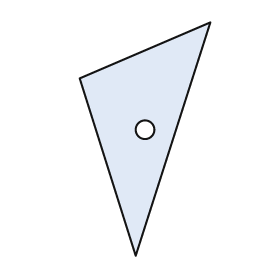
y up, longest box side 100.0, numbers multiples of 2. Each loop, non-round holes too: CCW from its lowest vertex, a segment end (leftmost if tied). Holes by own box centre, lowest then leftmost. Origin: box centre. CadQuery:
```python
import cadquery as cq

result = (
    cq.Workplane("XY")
    .moveTo(-4.0, -50.0)
    .lineTo(28.0, 50.0)
    .lineTo(-28.0, 26.0)
    .close()
    .moveTo(0.0, 4.0)
    .circle(4.0)
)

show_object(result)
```